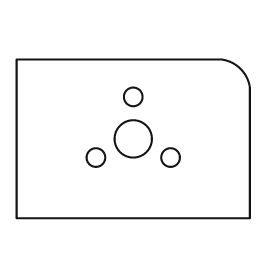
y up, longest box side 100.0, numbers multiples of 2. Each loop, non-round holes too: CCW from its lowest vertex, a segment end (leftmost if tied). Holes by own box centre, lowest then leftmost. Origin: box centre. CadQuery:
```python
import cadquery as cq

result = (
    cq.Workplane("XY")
    .moveTo(-50.0, -34.0)
    .lineTo(50.0, -34.0)
    .lineTo(50.0, 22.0)
    .threePointArc((46.0, 30.0), (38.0, 34.0))
    .lineTo(-50.0, 34.0)
    .close()
    .moveTo(-16.0, -8.0)
    .circle(4.0)
    .moveTo(16.0, -8.0)
    .circle(4.0)
    .moveTo(0.0, 0.0)
    .circle(8.0)
    .moveTo(0.0, 18.0)
    .circle(4.0)
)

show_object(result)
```